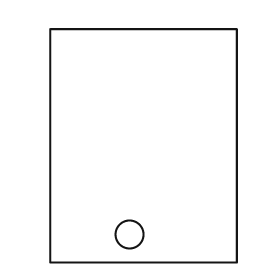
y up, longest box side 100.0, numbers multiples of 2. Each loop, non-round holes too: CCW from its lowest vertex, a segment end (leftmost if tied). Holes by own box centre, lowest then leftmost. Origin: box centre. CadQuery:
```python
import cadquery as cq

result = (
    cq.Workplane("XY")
    .moveTo(-40.0, -50.0)
    .lineTo(40.0, -50.0)
    .lineTo(40.0, 50.0)
    .lineTo(-40.0, 50.0)
    .close()
    .moveTo(-6.0, -38.0)
    .circle(6.0)
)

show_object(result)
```